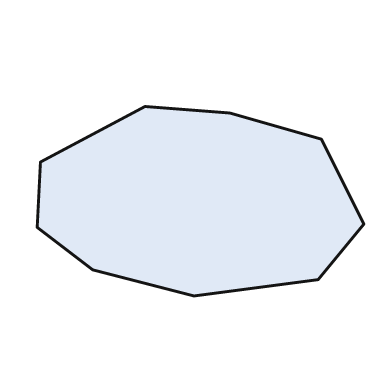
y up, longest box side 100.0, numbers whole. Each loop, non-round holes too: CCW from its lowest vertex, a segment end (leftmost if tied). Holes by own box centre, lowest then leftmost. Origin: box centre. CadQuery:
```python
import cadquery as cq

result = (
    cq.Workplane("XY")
    .moveTo(-2.0, -29.0)
    .lineTo(36.0, -24.0)
    .lineTo(50.0, -7.0)
    .lineTo(37.0, 19.0)
    .lineTo(9.0, 27.0)
    .lineTo(-17.0, 29.0)
    .lineTo(-49.0, 12.0)
    .lineTo(-50.0, -8.0)
    .lineTo(-33.0, -21.0)
    .close()
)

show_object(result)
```